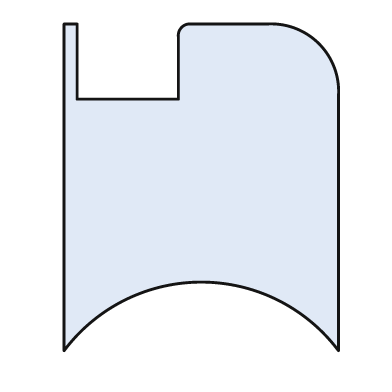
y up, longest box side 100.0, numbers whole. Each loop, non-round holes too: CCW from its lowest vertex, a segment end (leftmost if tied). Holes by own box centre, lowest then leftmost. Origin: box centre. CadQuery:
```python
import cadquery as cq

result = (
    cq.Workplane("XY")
    .moveTo(-42.0, -50.0)
    .threePointArc((0.0, -29.0), (42.0, -50.0))
    .lineTo(42.0, 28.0)
    .threePointArc((36.0, 44.0), (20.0, 50.0))
    .lineTo(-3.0, 50.0)
    .threePointArc((-6.0, 49.0), (-7.0, 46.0))
    .lineTo(-7.0, 27.0)
    .lineTo(-38.0, 27.0)
    .lineTo(-38.0, 50.0)
    .lineTo(-42.0, 50.0)
    .close()
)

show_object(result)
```